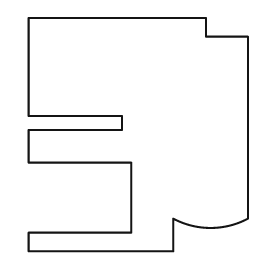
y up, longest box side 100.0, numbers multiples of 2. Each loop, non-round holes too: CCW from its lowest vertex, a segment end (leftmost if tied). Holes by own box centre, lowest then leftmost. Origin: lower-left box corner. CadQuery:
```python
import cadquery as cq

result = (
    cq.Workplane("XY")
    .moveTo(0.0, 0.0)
    .lineTo(62.0, 0.0)
    .lineTo(62.0, 14.0)
    .threePointArc((78.0, 10.0), (94.0, 14.0))
    .lineTo(94.0, 92.0)
    .lineTo(76.0, 92.0)
    .lineTo(76.0, 100.0)
    .lineTo(0.0, 100.0)
    .lineTo(0.0, 58.0)
    .lineTo(40.0, 58.0)
    .lineTo(40.0, 52.0)
    .lineTo(0.0, 52.0)
    .lineTo(0.0, 38.0)
    .lineTo(44.0, 38.0)
    .lineTo(44.0, 8.0)
    .lineTo(0.0, 8.0)
    .close()
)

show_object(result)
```